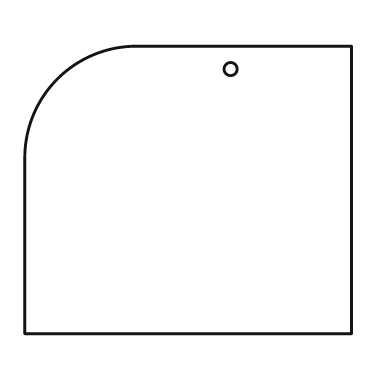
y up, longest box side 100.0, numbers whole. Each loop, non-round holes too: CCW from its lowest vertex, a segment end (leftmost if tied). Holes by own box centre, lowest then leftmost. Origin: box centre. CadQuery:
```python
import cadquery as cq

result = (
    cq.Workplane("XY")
    .moveTo(-50.0, -44.0)
    .lineTo(50.0, -44.0)
    .lineTo(50.0, 44.0)
    .lineTo(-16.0, 44.0)
    .threePointArc((-40.0, 34.0), (-50.0, 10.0))
    .close()
    .moveTo(13.0, 37.0)
    .circle(2.0)
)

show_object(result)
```